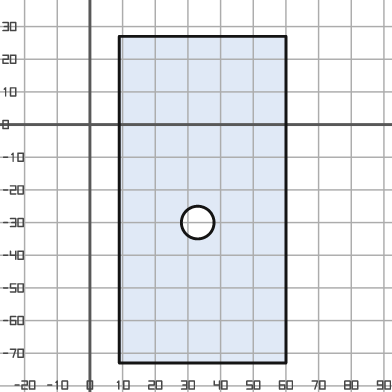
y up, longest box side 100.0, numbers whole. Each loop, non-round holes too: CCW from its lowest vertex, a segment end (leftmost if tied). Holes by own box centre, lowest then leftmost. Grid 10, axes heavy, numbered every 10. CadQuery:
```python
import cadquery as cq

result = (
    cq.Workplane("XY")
    .moveTo(9.0, -73.0)
    .lineTo(60.0, -73.0)
    .lineTo(60.0, 27.0)
    .lineTo(9.0, 27.0)
    .close()
    .moveTo(33.0, -30.0)
    .circle(5.0)
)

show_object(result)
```